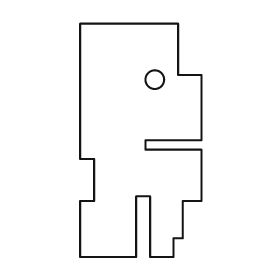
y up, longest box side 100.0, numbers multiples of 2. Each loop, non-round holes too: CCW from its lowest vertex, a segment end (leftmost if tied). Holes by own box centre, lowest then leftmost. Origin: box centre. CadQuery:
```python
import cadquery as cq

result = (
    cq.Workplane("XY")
    .moveTo(-26.0, -50.0)
    .lineTo(-2.0, -50.0)
    .lineTo(-2.0, -24.0)
    .lineTo(4.0, -24.0)
    .lineTo(4.0, -50.0)
    .lineTo(14.0, -50.0)
    .lineTo(14.0, -42.0)
    .lineTo(18.0, -42.0)
    .lineTo(18.0, -26.0)
    .lineTo(26.0, -26.0)
    .lineTo(26.0, -4.0)
    .lineTo(2.0, -4.0)
    .lineTo(2.0, 0.0)
    .lineTo(26.0, 0.0)
    .lineTo(26.0, 28.0)
    .lineTo(16.0, 28.0)
    .lineTo(16.0, 50.0)
    .lineTo(-26.0, 50.0)
    .lineTo(-26.0, -8.0)
    .lineTo(-20.0, -8.0)
    .lineTo(-20.0, -26.0)
    .lineTo(-26.0, -26.0)
    .close()
    .moveTo(6.0, 26.0)
    .circle(4.0)
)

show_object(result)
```